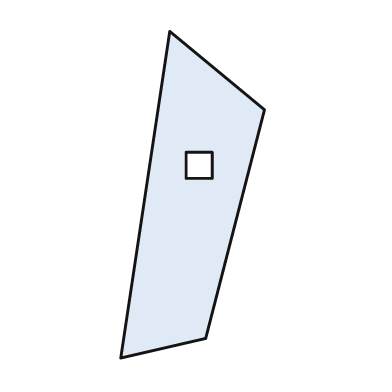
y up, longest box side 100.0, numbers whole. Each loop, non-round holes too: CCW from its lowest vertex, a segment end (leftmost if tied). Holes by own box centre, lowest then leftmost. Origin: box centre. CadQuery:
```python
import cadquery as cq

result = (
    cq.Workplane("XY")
    .moveTo(-22.0, -50.0)
    .lineTo(4.0, -44.0)
    .lineTo(22.0, 26.0)
    .lineTo(-7.0, 50.0)
    .close()
    .moveTo(-2.0, 5.0)
    .lineTo(6.0, 5.0)
    .lineTo(6.0, 13.0)
    .lineTo(-2.0, 13.0)
    .close()
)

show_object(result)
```